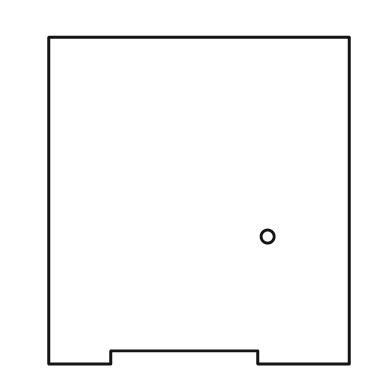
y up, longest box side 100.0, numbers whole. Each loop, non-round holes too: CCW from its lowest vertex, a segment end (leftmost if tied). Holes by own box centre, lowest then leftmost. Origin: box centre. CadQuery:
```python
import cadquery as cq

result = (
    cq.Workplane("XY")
    .moveTo(-46.0, -50.0)
    .lineTo(-27.0, -50.0)
    .lineTo(-27.0, -46.0)
    .lineTo(18.0, -46.0)
    .lineTo(18.0, -50.0)
    .lineTo(46.0, -50.0)
    .lineTo(46.0, 50.0)
    .lineTo(-46.0, 50.0)
    .close()
    .moveTo(21.0, -11.0)
    .circle(2.0)
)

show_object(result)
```